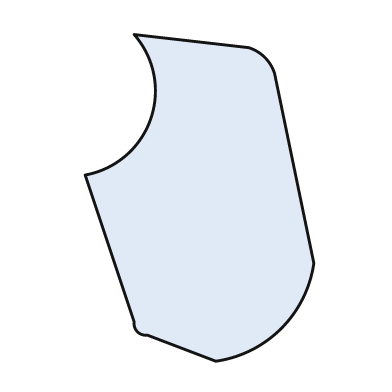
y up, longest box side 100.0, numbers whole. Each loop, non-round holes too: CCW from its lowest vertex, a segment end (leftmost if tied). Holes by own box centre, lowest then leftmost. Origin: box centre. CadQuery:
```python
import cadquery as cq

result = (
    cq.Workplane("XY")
    .moveTo(5.0, -50.0)
    .threePointArc((25.0, -40.0), (35.0, -20.0))
    .lineTo(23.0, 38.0)
    .threePointArc((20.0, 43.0), (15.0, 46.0))
    .lineTo(-20.0, 50.0)
    .threePointArc((-15.0, 24.0), (-35.0, 7.0))
    .lineTo(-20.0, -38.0)
    .threePointArc((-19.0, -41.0), (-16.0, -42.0))
    .close()
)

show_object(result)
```